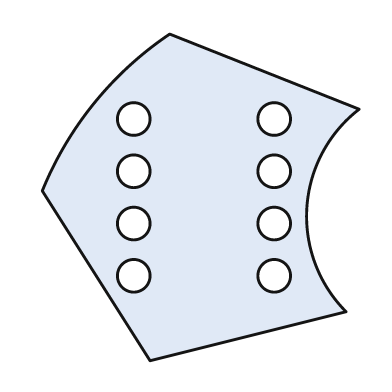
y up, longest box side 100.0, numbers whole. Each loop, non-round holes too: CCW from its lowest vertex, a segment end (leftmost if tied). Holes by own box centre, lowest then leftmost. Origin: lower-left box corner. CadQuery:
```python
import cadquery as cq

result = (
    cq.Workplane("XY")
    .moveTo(33.0, 0.0)
    .lineTo(93.0, 15.0)
    .threePointArc((81.0, 47.0), (97.0, 77.0))
    .lineTo(39.0, 100.0)
    .threePointArc((16.0, 79.0), (0.0, 52.0))
    .close()
    .moveTo(28.0, 26.0)
    .circle(5.0)
    .moveTo(71.0, 26.0)
    .circle(5.0)
    .moveTo(28.0, 42.0)
    .circle(5.0)
    .moveTo(71.0, 42.0)
    .circle(5.0)
    .moveTo(28.0, 58.0)
    .circle(5.0)
    .moveTo(71.0, 58.0)
    .circle(5.0)
    .moveTo(28.0, 74.0)
    .circle(5.0)
    .moveTo(71.0, 74.0)
    .circle(5.0)
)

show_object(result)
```